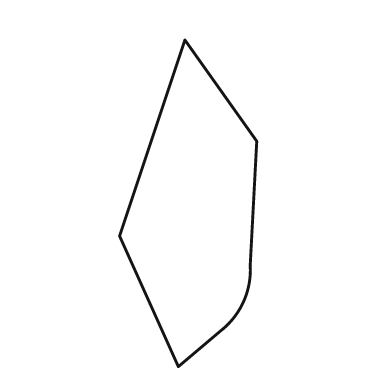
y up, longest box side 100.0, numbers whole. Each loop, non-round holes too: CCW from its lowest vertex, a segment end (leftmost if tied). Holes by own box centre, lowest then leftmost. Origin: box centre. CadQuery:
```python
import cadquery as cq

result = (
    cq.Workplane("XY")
    .moveTo(-3.0, -50.0)
    .lineTo(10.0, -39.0)
    .threePointArc((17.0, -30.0), (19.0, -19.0))
    .lineTo(21.0, 19.0)
    .lineTo(-1.0, 50.0)
    .lineTo(-21.0, -10.0)
    .close()
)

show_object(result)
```